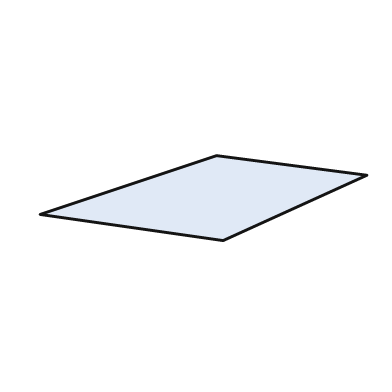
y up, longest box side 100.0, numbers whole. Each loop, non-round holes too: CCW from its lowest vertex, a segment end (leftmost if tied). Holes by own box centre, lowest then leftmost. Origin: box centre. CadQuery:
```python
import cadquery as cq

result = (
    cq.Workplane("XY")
    .moveTo(6.0, -13.0)
    .lineTo(50.0, 7.0)
    .lineTo(4.0, 13.0)
    .lineTo(-50.0, -5.0)
    .close()
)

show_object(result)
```